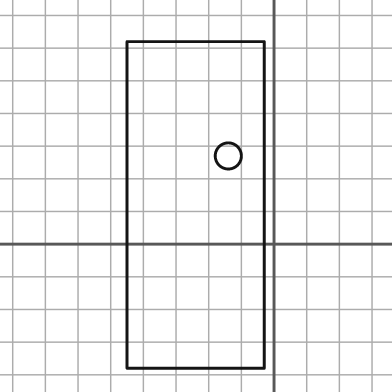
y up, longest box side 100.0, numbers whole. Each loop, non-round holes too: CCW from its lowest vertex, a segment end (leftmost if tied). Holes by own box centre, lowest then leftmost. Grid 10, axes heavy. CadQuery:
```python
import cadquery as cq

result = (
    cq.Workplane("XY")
    .moveTo(-45.0, -38.0)
    .lineTo(-3.0, -38.0)
    .lineTo(-3.0, 62.0)
    .lineTo(-45.0, 62.0)
    .close()
    .moveTo(-14.0, 27.0)
    .circle(4.0)
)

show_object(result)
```